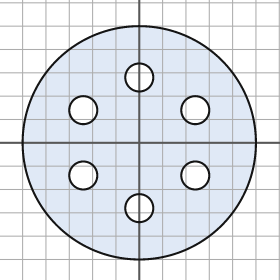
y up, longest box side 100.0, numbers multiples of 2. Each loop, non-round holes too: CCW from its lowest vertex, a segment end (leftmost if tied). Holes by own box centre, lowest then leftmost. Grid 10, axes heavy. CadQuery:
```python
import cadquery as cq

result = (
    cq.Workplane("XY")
    .moveTo(0.0, 0.0)
    .circle(50.0)
    .moveTo(0.0, -28.0)
    .circle(6.0)
    .moveTo(-24.0, -14.0)
    .circle(6.0)
    .moveTo(24.0, -14.0)
    .circle(6.0)
    .moveTo(-24.0, 14.0)
    .circle(6.0)
    .moveTo(24.0, 14.0)
    .circle(6.0)
    .moveTo(0.0, 28.0)
    .circle(6.0)
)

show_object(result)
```